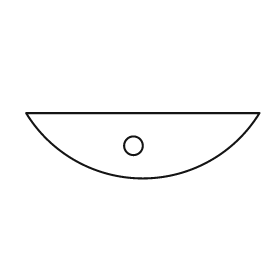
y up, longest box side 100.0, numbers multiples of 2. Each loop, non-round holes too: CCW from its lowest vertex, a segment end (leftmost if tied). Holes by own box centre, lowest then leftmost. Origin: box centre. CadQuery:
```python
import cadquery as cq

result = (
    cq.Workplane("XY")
    .moveTo(-50.0, 14.0)
    .threePointArc((0.0, -14.0), (50.0, 14.0))
    .close()
    .moveTo(-4.0, 0.0)
    .circle(4.0)
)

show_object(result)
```